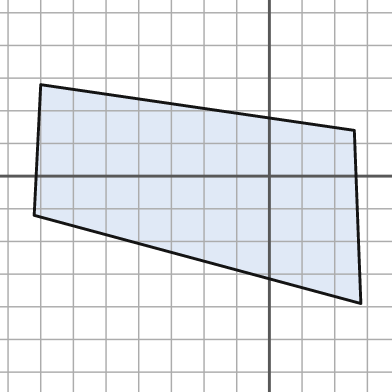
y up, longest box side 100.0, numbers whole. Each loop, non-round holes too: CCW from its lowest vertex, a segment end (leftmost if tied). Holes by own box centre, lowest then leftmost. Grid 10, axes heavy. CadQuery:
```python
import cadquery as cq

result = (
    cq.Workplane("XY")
    .moveTo(28.0, -39.0)
    .lineTo(26.0, 14.0)
    .lineTo(-70.0, 28.0)
    .lineTo(-72.0, -12.0)
    .close()
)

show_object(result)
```